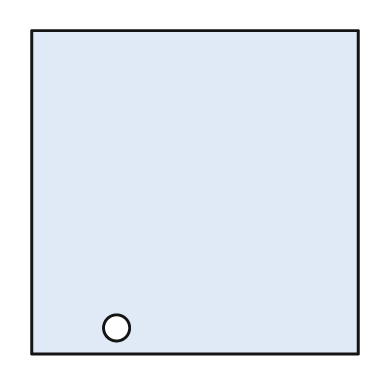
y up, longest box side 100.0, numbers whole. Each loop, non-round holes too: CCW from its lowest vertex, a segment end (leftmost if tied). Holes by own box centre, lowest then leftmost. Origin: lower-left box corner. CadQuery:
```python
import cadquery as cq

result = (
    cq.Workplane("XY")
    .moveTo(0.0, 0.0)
    .lineTo(100.0, 0.0)
    .lineTo(100.0, 99.0)
    .lineTo(0.0, 99.0)
    .close()
    .moveTo(26.0, 8.0)
    .circle(4.0)
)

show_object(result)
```